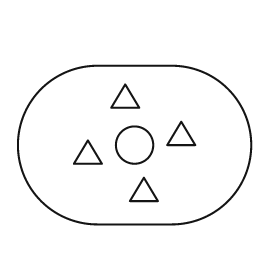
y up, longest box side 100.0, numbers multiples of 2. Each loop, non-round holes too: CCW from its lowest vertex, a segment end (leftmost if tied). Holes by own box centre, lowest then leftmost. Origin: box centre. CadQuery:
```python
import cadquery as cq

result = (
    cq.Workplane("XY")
    .moveTo(-16.0, -34.0)
    .lineTo(16.0, -34.0)
    .threePointArc((50.0, 0.0), (16.0, 34.0))
    .lineTo(-16.0, 34.0)
    .threePointArc((-50.0, 0.0), (-16.0, -34.0))
    .close()
    .moveTo(-2.0, -24.0)
    .lineTo(10.0, -24.0)
    .lineTo(4.0, -14.0)
    .close()
    .moveTo(-26.0, -8.0)
    .lineTo(-14.0, -8.0)
    .lineTo(-20.0, 2.0)
    .close()
    .moveTo(0.0, 0.0)
    .circle(8.0)
    .moveTo(14.0, 0.0)
    .lineTo(26.0, 0.0)
    .lineTo(20.0, 10.0)
    .close()
    .moveTo(-10.0, 16.0)
    .lineTo(2.0, 16.0)
    .lineTo(-4.0, 26.0)
    .close()
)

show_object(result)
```